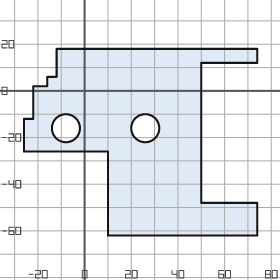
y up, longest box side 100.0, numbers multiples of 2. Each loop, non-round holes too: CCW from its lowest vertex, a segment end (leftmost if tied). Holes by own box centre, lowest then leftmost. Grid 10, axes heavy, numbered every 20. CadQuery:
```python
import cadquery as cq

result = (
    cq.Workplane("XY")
    .moveTo(10.0, -62.0)
    .lineTo(74.0, -62.0)
    .lineTo(74.0, -48.0)
    .lineTo(50.0, -48.0)
    .lineTo(50.0, 12.0)
    .lineTo(74.0, 12.0)
    .lineTo(74.0, 18.0)
    .lineTo(-12.0, 18.0)
    .lineTo(-12.0, 6.0)
    .lineTo(-16.0, 6.0)
    .lineTo(-16.0, 2.0)
    .lineTo(-22.0, 2.0)
    .lineTo(-22.0, -12.0)
    .lineTo(-26.0, -12.0)
    .lineTo(-26.0, -26.0)
    .lineTo(10.0, -26.0)
    .close()
    .moveTo(-8.0, -16.0)
    .circle(6.0)
    .moveTo(26.0, -16.0)
    .circle(6.0)
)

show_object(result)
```